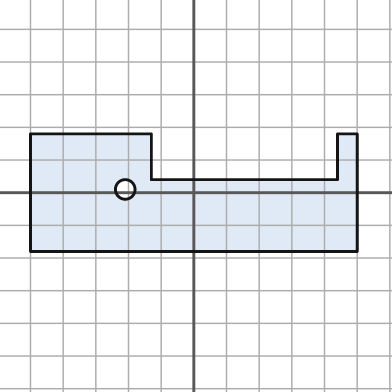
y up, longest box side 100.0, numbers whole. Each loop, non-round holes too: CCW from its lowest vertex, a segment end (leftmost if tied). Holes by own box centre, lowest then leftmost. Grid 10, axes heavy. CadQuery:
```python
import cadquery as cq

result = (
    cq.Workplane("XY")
    .moveTo(-50.0, -18.0)
    .lineTo(50.0, -18.0)
    .lineTo(50.0, 18.0)
    .lineTo(44.0, 18.0)
    .lineTo(44.0, 4.0)
    .lineTo(-13.0, 4.0)
    .lineTo(-13.0, 18.0)
    .lineTo(-50.0, 18.0)
    .close()
    .moveTo(-21.0, 1.0)
    .circle(3.0)
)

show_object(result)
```